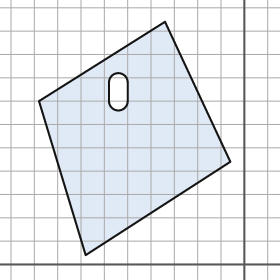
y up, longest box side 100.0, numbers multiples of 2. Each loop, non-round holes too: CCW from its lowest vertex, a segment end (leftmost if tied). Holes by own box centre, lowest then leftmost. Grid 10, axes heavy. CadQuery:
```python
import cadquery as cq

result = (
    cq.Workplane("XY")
    .moveTo(-68.0, 4.0)
    .lineTo(-6.0, 44.0)
    .lineTo(-34.0, 104.0)
    .lineTo(-88.0, 70.0)
    .close()
    .moveTo(-58.0, 70.0)
    .threePointArc((-54.0, 66.0), (-50.0, 70.0))
    .lineTo(-50.0, 78.0)
    .threePointArc((-54.0, 82.0), (-58.0, 78.0))
    .close()
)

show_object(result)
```